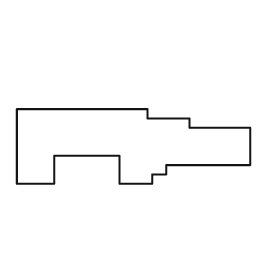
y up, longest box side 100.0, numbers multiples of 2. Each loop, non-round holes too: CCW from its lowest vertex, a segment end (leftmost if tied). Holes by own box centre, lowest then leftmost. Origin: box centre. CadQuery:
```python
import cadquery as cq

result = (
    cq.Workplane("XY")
    .moveTo(-50.0, -16.0)
    .lineTo(-34.0, -16.0)
    .lineTo(-34.0, -4.0)
    .lineTo(-6.0, -4.0)
    .lineTo(-6.0, -16.0)
    .lineTo(8.0, -16.0)
    .lineTo(8.0, -12.0)
    .lineTo(14.0, -12.0)
    .lineTo(14.0, -8.0)
    .lineTo(50.0, -8.0)
    .lineTo(50.0, 8.0)
    .lineTo(24.0, 8.0)
    .lineTo(24.0, 12.0)
    .lineTo(6.0, 12.0)
    .lineTo(6.0, 16.0)
    .lineTo(-50.0, 16.0)
    .close()
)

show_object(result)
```